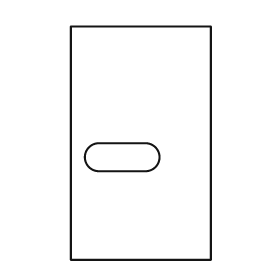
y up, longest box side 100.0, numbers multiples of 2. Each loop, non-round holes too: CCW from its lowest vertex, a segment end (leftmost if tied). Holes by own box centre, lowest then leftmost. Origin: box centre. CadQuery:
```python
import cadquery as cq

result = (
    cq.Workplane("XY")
    .moveTo(-30.0, -50.0)
    .lineTo(30.0, -50.0)
    .lineTo(30.0, 50.0)
    .lineTo(-30.0, 50.0)
    .close()
    .moveTo(-18.0, -12.0)
    .lineTo(2.0, -12.0)
    .threePointArc((8.0, -6.0), (2.0, 0.0))
    .lineTo(-18.0, 0.0)
    .threePointArc((-24.0, -6.0), (-18.0, -12.0))
    .close()
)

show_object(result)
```